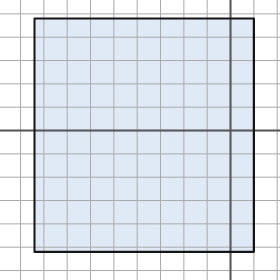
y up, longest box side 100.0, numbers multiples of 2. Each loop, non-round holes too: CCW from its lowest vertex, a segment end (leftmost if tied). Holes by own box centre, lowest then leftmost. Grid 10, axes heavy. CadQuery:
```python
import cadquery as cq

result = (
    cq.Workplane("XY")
    .moveTo(-84.0, -52.0)
    .lineTo(10.0, -52.0)
    .lineTo(10.0, 48.0)
    .lineTo(-84.0, 48.0)
    .close()
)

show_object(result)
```